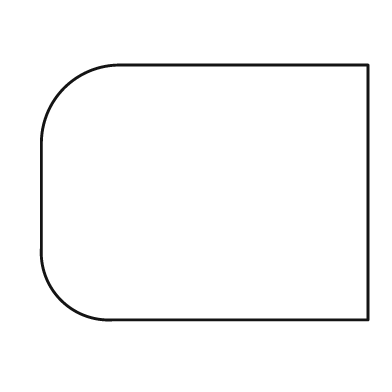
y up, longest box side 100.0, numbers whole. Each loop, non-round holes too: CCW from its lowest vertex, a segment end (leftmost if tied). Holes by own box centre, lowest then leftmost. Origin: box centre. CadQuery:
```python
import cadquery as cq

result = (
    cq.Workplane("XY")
    .moveTo(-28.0, -39.0)
    .lineTo(50.0, -39.0)
    .lineTo(50.0, 39.0)
    .lineTo(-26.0, 39.0)
    .threePointArc((-43.0, 32.0), (-50.0, 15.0))
    .lineTo(-50.0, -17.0)
    .threePointArc((-44.0, -33.0), (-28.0, -39.0))
    .close()
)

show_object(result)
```